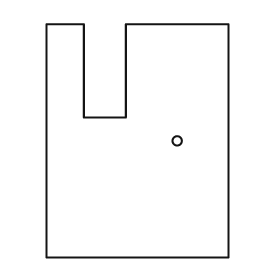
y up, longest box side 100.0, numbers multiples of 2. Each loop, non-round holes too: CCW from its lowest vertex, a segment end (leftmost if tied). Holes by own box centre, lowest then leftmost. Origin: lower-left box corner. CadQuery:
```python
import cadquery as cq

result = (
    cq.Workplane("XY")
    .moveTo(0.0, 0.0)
    .lineTo(78.0, 0.0)
    .lineTo(78.0, 100.0)
    .lineTo(34.0, 100.0)
    .lineTo(34.0, 60.0)
    .lineTo(16.0, 60.0)
    .lineTo(16.0, 100.0)
    .lineTo(0.0, 100.0)
    .close()
    .moveTo(56.0, 50.0)
    .circle(2.0)
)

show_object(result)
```